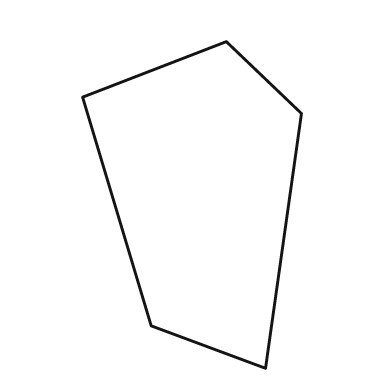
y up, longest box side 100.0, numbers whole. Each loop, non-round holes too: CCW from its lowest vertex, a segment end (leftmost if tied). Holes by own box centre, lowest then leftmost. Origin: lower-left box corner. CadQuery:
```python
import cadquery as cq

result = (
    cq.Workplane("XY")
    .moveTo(56.0, 0.0)
    .lineTo(67.0, 78.0)
    .lineTo(44.0, 100.0)
    .lineTo(0.0, 83.0)
    .lineTo(21.0, 13.0)
    .close()
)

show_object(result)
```